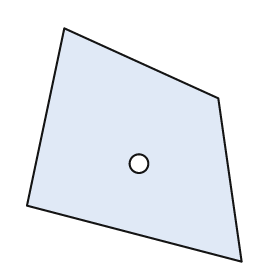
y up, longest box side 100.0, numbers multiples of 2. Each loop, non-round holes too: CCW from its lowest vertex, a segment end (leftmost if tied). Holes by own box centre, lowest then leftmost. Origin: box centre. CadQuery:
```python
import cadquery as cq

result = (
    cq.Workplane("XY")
    .moveTo(46.0, -50.0)
    .lineTo(36.0, 20.0)
    .lineTo(-30.0, 50.0)
    .lineTo(-46.0, -26.0)
    .close()
    .moveTo(2.0, -8.0)
    .circle(4.0)
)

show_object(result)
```